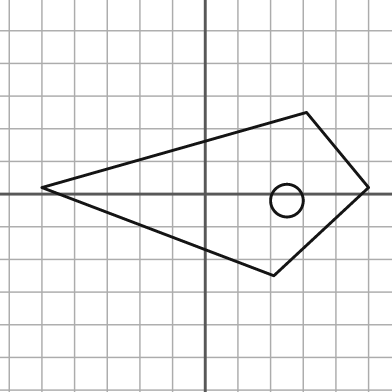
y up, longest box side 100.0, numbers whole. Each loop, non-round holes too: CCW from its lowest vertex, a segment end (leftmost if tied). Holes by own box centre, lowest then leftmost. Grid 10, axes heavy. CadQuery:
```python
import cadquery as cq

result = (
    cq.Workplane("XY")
    .moveTo(21.0, -25.0)
    .lineTo(50.0, 2.0)
    .lineTo(31.0, 25.0)
    .lineTo(-50.0, 2.0)
    .close()
    .moveTo(25.0, -2.0)
    .circle(5.0)
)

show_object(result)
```